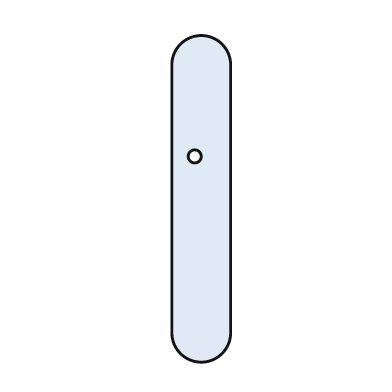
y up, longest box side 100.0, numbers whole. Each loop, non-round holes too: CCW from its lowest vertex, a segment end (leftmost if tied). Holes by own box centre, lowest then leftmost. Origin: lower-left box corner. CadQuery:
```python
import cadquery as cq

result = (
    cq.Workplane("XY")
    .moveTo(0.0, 9.0)
    .threePointArc((9.0, 0.0), (18.0, 9.0))
    .lineTo(18.0, 91.0)
    .threePointArc((9.0, 100.0), (0.0, 91.0))
    .close()
    .moveTo(7.0, 63.0)
    .circle(2.0)
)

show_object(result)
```